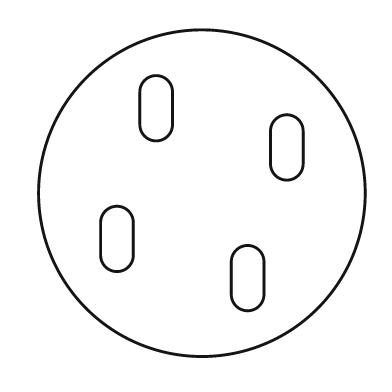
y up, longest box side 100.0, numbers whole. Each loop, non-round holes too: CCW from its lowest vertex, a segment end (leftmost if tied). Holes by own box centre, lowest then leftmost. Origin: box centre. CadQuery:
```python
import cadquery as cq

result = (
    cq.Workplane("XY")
    .moveTo(0.0, 0.0)
    .circle(50.0)
    .moveTo(9.0, -31.0)
    .threePointArc((14.0, -36.0), (19.0, -31.0))
    .lineTo(19.0, -21.0)
    .threePointArc((14.0, -16.0), (9.0, -21.0))
    .close()
    .moveTo(-31.0, -19.0)
    .threePointArc((-26.0, -24.0), (-21.0, -19.0))
    .lineTo(-21.0, -9.0)
    .threePointArc((-26.0, -4.0), (-31.0, -9.0))
    .close()
    .moveTo(21.0, 9.0)
    .threePointArc((26.0, 4.0), (31.0, 9.0))
    .lineTo(31.0, 19.0)
    .threePointArc((26.0, 24.0), (21.0, 19.0))
    .close()
    .moveTo(-19.0, 21.0)
    .threePointArc((-14.0, 16.0), (-9.0, 21.0))
    .lineTo(-9.0, 31.0)
    .threePointArc((-14.0, 36.0), (-19.0, 31.0))
    .close()
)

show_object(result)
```